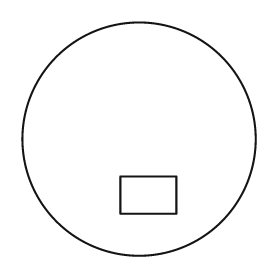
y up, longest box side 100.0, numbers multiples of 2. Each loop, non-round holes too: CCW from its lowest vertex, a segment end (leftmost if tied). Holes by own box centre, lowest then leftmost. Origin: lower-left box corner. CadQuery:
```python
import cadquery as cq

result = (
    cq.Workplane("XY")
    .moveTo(50.0, 50.0)
    .circle(50.0)
    .moveTo(42.0, 18.0)
    .lineTo(66.0, 18.0)
    .lineTo(66.0, 34.0)
    .lineTo(42.0, 34.0)
    .close()
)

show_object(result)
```